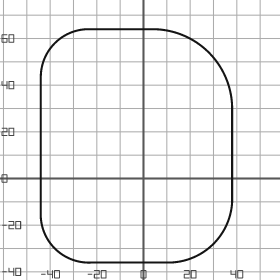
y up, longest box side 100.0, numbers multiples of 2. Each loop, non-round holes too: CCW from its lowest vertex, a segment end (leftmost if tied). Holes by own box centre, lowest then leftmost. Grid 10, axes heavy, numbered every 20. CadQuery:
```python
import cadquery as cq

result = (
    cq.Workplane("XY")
    .moveTo(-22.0, -36.0)
    .lineTo(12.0, -36.0)
    .threePointArc((30.0, -28.0), (38.0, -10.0))
    .lineTo(38.0, 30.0)
    .threePointArc((28.0, 54.0), (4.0, 64.0))
    .lineTo(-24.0, 64.0)
    .threePointArc((-38.0, 58.0), (-44.0, 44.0))
    .lineTo(-44.0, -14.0)
    .threePointArc((-38.0, -30.0), (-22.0, -36.0))
    .close()
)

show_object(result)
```